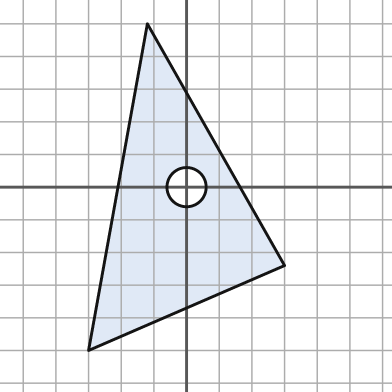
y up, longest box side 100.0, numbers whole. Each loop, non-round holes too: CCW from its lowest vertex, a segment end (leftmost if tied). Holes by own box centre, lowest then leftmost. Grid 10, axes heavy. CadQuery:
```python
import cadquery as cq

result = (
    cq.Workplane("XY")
    .moveTo(-30.0, -50.0)
    .lineTo(30.0, -24.0)
    .lineTo(-12.0, 50.0)
    .close()
    .moveTo(0.0, 0.0)
    .circle(6.0)
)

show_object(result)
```